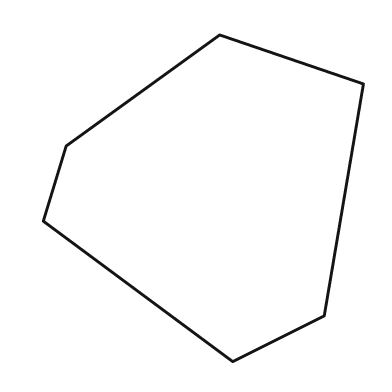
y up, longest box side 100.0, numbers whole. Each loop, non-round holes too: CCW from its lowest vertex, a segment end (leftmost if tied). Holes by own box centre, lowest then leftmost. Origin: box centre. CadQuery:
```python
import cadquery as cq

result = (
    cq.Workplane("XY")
    .moveTo(9.0, -50.0)
    .lineTo(37.0, -36.0)
    .lineTo(49.0, 35.0)
    .lineTo(5.0, 50.0)
    .lineTo(-42.0, 16.0)
    .lineTo(-49.0, -7.0)
    .close()
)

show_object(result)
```